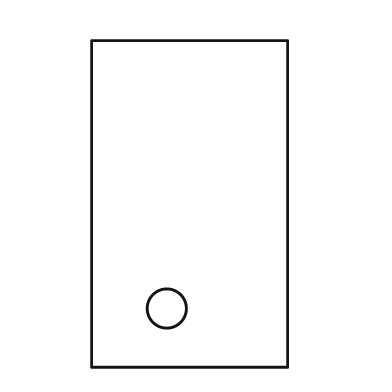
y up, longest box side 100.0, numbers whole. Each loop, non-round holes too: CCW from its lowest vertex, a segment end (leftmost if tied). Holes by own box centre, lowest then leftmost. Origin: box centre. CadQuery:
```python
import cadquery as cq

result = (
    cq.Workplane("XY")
    .moveTo(-30.0, -50.0)
    .lineTo(30.0, -50.0)
    .lineTo(30.0, 50.0)
    .lineTo(-30.0, 50.0)
    .close()
    .moveTo(-7.0, -32.0)
    .circle(6.0)
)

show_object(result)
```